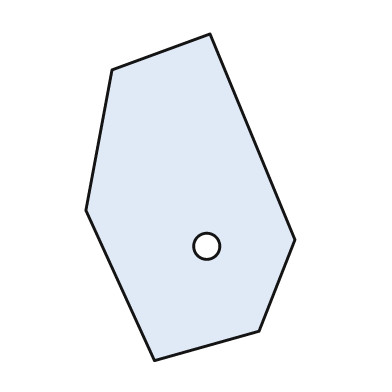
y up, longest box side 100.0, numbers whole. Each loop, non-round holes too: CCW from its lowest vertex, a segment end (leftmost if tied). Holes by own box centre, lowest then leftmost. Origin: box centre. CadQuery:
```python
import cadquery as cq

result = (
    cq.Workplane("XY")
    .moveTo(-11.0, -50.0)
    .lineTo(21.0, -41.0)
    .lineTo(32.0, -13.0)
    .lineTo(6.0, 50.0)
    .lineTo(-24.0, 39.0)
    .lineTo(-32.0, -4.0)
    .close()
    .moveTo(5.0, -15.0)
    .circle(4.0)
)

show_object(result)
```